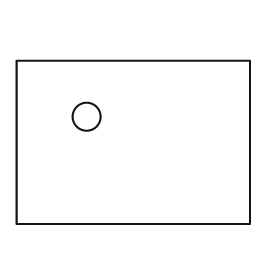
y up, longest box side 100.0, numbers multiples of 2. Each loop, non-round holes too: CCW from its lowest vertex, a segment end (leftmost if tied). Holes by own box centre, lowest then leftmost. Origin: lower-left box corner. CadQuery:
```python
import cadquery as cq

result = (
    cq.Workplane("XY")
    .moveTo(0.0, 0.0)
    .lineTo(100.0, 0.0)
    .lineTo(100.0, 70.0)
    .lineTo(0.0, 70.0)
    .close()
    .moveTo(30.0, 46.0)
    .circle(6.0)
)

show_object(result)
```